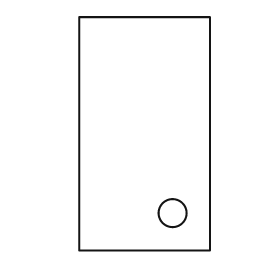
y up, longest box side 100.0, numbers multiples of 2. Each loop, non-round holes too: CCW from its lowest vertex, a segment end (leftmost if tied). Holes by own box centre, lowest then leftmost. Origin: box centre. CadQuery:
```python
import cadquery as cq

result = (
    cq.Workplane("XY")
    .moveTo(-28.0, -50.0)
    .lineTo(28.0, -50.0)
    .lineTo(28.0, 50.0)
    .lineTo(-28.0, 50.0)
    .close()
    .moveTo(12.0, -34.0)
    .circle(6.0)
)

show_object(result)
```